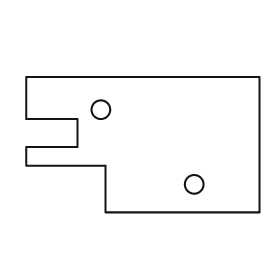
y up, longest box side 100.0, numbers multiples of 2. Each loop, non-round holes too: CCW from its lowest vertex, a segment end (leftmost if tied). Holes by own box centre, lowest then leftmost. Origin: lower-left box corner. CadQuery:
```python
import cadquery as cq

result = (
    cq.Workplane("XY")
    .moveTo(34.0, 0.0)
    .lineTo(100.0, 0.0)
    .lineTo(100.0, 58.0)
    .lineTo(0.0, 58.0)
    .lineTo(0.0, 40.0)
    .lineTo(22.0, 40.0)
    .lineTo(22.0, 28.0)
    .lineTo(0.0, 28.0)
    .lineTo(0.0, 20.0)
    .lineTo(34.0, 20.0)
    .close()
    .moveTo(72.0, 12.0)
    .circle(4.0)
    .moveTo(32.0, 44.0)
    .circle(4.0)
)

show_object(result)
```